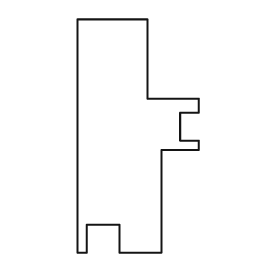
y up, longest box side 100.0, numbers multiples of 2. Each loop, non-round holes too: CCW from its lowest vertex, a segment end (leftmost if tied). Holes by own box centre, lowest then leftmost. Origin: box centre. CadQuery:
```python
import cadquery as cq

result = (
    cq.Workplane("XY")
    .moveTo(-26.0, -50.0)
    .lineTo(-22.0, -50.0)
    .lineTo(-22.0, -38.0)
    .lineTo(-8.0, -38.0)
    .lineTo(-8.0, -50.0)
    .lineTo(10.0, -50.0)
    .lineTo(10.0, -6.0)
    .lineTo(26.0, -6.0)
    .lineTo(26.0, -2.0)
    .lineTo(18.0, -2.0)
    .lineTo(18.0, 10.0)
    .lineTo(26.0, 10.0)
    .lineTo(26.0, 16.0)
    .lineTo(4.0, 16.0)
    .lineTo(4.0, 50.0)
    .lineTo(-26.0, 50.0)
    .close()
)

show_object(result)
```